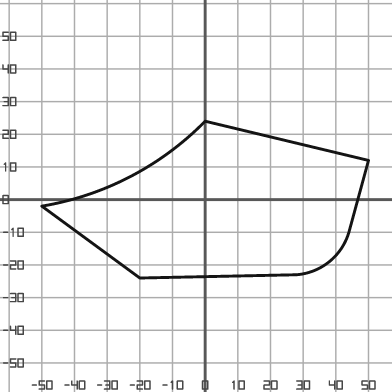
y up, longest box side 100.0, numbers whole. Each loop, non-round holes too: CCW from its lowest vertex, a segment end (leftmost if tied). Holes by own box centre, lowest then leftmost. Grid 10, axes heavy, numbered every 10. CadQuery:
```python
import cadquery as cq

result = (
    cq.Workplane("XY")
    .moveTo(-20.0, -24.0)
    .lineTo(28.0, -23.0)
    .threePointArc((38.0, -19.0), (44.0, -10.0))
    .lineTo(50.0, 12.0)
    .lineTo(0.0, 24.0)
    .threePointArc((-23.0, 7.0), (-50.0, -2.0))
    .close()
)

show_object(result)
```